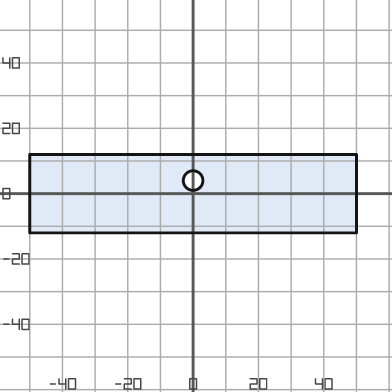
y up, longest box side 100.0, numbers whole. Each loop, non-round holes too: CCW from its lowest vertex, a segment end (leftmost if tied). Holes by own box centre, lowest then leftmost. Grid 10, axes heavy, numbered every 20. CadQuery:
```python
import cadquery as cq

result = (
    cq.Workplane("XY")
    .moveTo(-50.0, -12.0)
    .lineTo(50.0, -12.0)
    .lineTo(50.0, 12.0)
    .lineTo(-50.0, 12.0)
    .close()
    .moveTo(0.0, 4.0)
    .circle(3.0)
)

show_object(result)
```